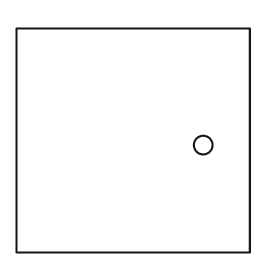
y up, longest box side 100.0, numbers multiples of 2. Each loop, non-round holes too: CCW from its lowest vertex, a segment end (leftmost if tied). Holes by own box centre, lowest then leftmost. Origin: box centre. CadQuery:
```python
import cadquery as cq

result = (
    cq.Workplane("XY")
    .moveTo(-50.0, -48.0)
    .lineTo(50.0, -48.0)
    .lineTo(50.0, 48.0)
    .lineTo(-50.0, 48.0)
    .close()
    .moveTo(30.0, -2.0)
    .circle(4.0)
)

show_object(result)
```